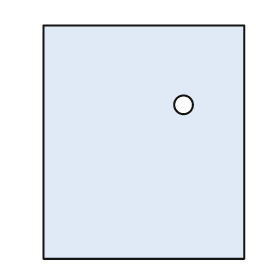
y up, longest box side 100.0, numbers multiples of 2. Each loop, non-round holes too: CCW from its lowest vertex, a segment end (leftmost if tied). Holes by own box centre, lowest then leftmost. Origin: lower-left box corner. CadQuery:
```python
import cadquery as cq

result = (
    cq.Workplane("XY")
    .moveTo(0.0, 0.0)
    .lineTo(86.0, 0.0)
    .lineTo(86.0, 100.0)
    .lineTo(0.0, 100.0)
    .close()
    .moveTo(60.0, 66.0)
    .circle(4.0)
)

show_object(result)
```